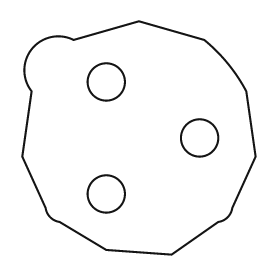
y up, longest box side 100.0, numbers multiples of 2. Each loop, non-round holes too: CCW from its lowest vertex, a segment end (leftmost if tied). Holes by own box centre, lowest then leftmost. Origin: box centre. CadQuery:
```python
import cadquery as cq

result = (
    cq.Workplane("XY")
    .moveTo(14.0, -50.0)
    .lineTo(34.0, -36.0)
    .threePointArc((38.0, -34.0), (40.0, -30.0))
    .lineTo(50.0, -8.0)
    .lineTo(46.0, 20.0)
    .threePointArc((38.0, 32.0), (28.0, 42.0))
    .lineTo(0.0, 50.0)
    .lineTo(-28.0, 42.0)
    .threePointArc((-46.0, 38.0), (-46.0, 20.0))
    .lineTo(-50.0, -8.0)
    .lineTo(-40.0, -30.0)
    .threePointArc((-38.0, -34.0), (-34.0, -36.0))
    .lineTo(-14.0, -48.0)
    .close()
    .moveTo(-14.0, -24.0)
    .circle(8.0)
    .moveTo(26.0, 0.0)
    .circle(8.0)
    .moveTo(-14.0, 24.0)
    .circle(8.0)
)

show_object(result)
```